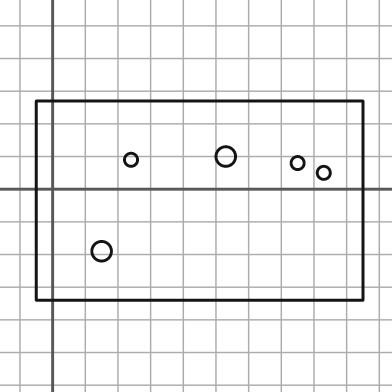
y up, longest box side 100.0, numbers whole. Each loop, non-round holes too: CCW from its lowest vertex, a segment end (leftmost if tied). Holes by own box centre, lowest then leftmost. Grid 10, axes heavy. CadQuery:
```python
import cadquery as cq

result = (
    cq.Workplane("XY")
    .moveTo(-5.0, -34.0)
    .lineTo(95.0, -34.0)
    .lineTo(95.0, 27.0)
    .lineTo(-5.0, 27.0)
    .close()
    .moveTo(15.0, -19.0)
    .circle(3.0)
    .moveTo(83.0, 5.0)
    .circle(2.0)
    .moveTo(75.0, 8.0)
    .circle(2.0)
    .moveTo(24.0, 9.0)
    .circle(2.0)
    .moveTo(53.0, 10.0)
    .circle(3.0)
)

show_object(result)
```